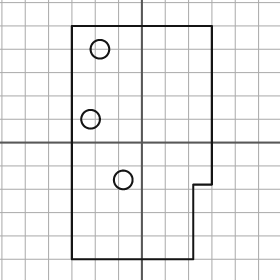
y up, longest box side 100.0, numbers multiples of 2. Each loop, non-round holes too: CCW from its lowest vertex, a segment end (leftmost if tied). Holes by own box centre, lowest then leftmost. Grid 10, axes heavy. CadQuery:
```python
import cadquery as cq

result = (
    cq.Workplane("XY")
    .moveTo(-30.0, -50.0)
    .lineTo(22.0, -50.0)
    .lineTo(22.0, -18.0)
    .lineTo(30.0, -18.0)
    .lineTo(30.0, 50.0)
    .lineTo(-30.0, 50.0)
    .close()
    .moveTo(-8.0, -16.0)
    .circle(4.0)
    .moveTo(-22.0, 10.0)
    .circle(4.0)
    .moveTo(-18.0, 40.0)
    .circle(4.0)
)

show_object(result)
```